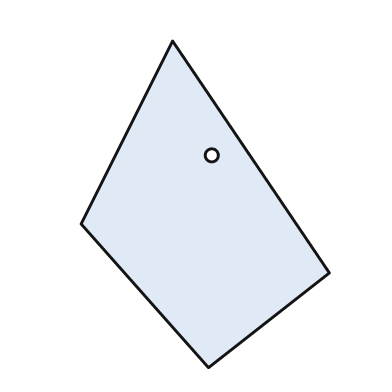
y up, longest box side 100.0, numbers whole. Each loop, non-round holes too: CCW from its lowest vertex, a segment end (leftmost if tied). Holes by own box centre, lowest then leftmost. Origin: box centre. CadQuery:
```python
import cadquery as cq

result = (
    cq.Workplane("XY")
    .moveTo(1.0, -50.0)
    .lineTo(38.0, -21.0)
    .lineTo(-10.0, 50.0)
    .lineTo(-38.0, -6.0)
    .close()
    .moveTo(2.0, 15.0)
    .circle(2.0)
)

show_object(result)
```